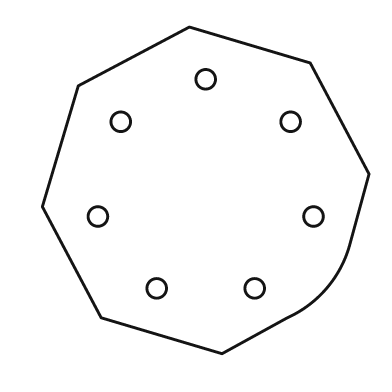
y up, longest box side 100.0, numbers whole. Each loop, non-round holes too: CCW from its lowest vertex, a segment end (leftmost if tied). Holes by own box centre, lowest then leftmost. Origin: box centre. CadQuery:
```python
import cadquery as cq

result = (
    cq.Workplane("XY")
    .moveTo(5.0, -50.0)
    .lineTo(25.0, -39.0)
    .threePointArc((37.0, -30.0), (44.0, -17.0))
    .lineTo(50.0, 5.0)
    .lineTo(32.0, 39.0)
    .lineTo(-5.0, 50.0)
    .lineTo(-39.0, 32.0)
    .lineTo(-50.0, -5.0)
    .lineTo(-32.0, -39.0)
    .close()
    .moveTo(-15.0, -30.0)
    .circle(3.0)
    .moveTo(15.0, -30.0)
    .circle(3.0)
    .moveTo(-33.0, -8.0)
    .circle(3.0)
    .moveTo(33.0, -8.0)
    .circle(3.0)
    .moveTo(-26.0, 21.0)
    .circle(3.0)
    .moveTo(26.0, 21.0)
    .circle(3.0)
    .moveTo(0.0, 34.0)
    .circle(3.0)
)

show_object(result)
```